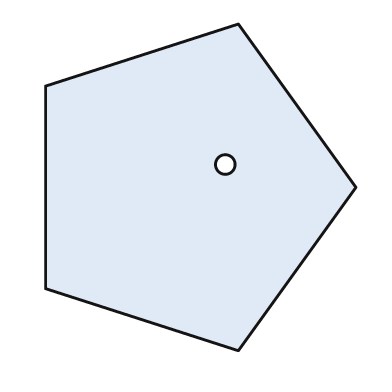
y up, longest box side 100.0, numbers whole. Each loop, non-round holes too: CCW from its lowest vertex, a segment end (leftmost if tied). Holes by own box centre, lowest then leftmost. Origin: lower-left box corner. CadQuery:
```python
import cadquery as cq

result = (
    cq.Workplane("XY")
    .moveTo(59.0, 0.0)
    .lineTo(95.0, 50.0)
    .lineTo(59.0, 100.0)
    .lineTo(0.0, 81.0)
    .lineTo(0.0, 19.0)
    .close()
    .moveTo(55.0, 57.0)
    .circle(3.0)
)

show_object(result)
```